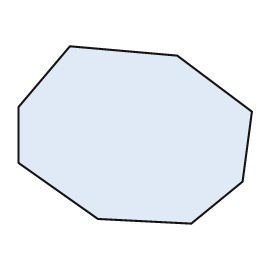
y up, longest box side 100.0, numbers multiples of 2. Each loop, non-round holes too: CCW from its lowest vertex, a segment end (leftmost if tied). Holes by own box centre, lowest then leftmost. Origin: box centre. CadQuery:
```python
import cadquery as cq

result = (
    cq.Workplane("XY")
    .moveTo(24.0, -38.0)
    .lineTo(46.0, -20.0)
    .lineTo(50.0, 10.0)
    .lineTo(18.0, 34.0)
    .lineTo(-28.0, 38.0)
    .lineTo(-50.0, 12.0)
    .lineTo(-50.0, -12.0)
    .lineTo(-16.0, -36.0)
    .close()
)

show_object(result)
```